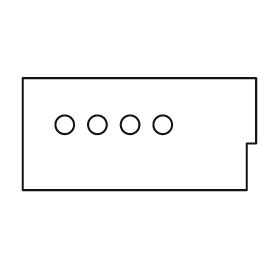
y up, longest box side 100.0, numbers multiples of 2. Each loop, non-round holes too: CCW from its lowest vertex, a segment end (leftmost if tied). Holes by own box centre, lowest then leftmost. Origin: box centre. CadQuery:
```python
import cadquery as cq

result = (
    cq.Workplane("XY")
    .moveTo(-50.0, -24.0)
    .lineTo(46.0, -24.0)
    .lineTo(46.0, -4.0)
    .lineTo(50.0, -4.0)
    .lineTo(50.0, 24.0)
    .lineTo(-50.0, 24.0)
    .close()
    .moveTo(-32.0, 4.0)
    .circle(4.0)
    .moveTo(-18.0, 4.0)
    .circle(4.0)
    .moveTo(-4.0, 4.0)
    .circle(4.0)
    .moveTo(10.0, 4.0)
    .circle(4.0)
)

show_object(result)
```